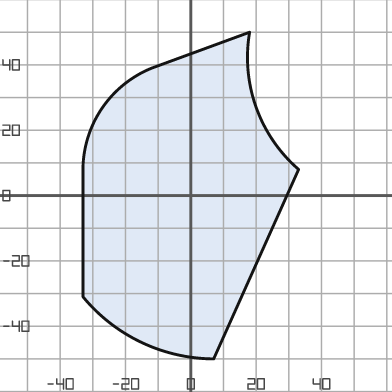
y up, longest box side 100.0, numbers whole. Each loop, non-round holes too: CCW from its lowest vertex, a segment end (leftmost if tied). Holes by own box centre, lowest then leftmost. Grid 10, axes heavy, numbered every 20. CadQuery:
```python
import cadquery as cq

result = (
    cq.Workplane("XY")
    .moveTo(7.0, -50.0)
    .lineTo(33.0, 8.0)
    .threePointArc((20.0, 27.0), (18.0, 50.0))
    .lineTo(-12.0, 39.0)
    .threePointArc((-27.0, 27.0), (-33.0, 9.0))
    .lineTo(-33.0, -31.0)
    .threePointArc((-15.0, -45.0), (7.0, -50.0))
    .close()
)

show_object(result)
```